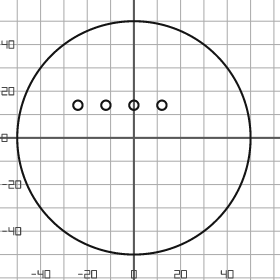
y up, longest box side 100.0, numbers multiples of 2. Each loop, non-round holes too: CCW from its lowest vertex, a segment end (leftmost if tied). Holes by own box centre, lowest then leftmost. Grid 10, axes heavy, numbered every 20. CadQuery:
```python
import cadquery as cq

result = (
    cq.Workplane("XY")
    .moveTo(0.0, 0.0)
    .circle(50.0)
    .moveTo(-24.0, 14.0)
    .circle(2.0)
    .moveTo(-12.0, 14.0)
    .circle(2.0)
    .moveTo(0.0, 14.0)
    .circle(2.0)
    .moveTo(12.0, 14.0)
    .circle(2.0)
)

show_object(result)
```